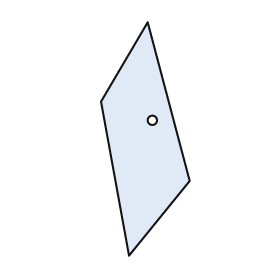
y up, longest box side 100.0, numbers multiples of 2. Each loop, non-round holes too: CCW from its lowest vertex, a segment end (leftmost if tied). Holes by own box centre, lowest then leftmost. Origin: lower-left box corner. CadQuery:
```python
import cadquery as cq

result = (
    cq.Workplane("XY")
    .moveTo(12.0, 0.0)
    .lineTo(38.0, 32.0)
    .lineTo(20.0, 100.0)
    .lineTo(0.0, 66.0)
    .close()
    .moveTo(22.0, 58.0)
    .circle(2.0)
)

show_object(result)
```